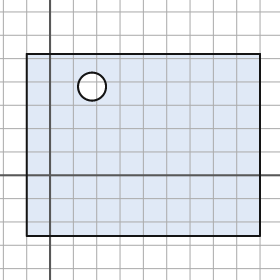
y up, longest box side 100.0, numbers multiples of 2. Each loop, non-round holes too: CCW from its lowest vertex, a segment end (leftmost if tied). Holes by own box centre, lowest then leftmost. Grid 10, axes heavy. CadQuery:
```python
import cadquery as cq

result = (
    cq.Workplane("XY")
    .moveTo(-10.0, -26.0)
    .lineTo(90.0, -26.0)
    .lineTo(90.0, 52.0)
    .lineTo(-10.0, 52.0)
    .close()
    .moveTo(18.0, 38.0)
    .circle(6.0)
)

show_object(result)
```